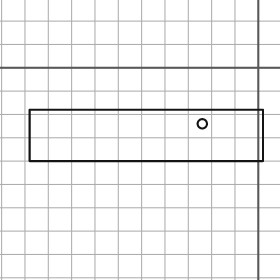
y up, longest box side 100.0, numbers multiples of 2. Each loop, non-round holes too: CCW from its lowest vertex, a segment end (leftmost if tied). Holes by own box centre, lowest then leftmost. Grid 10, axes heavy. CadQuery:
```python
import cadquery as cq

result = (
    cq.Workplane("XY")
    .moveTo(-98.0, -40.0)
    .lineTo(2.0, -40.0)
    .lineTo(2.0, -18.0)
    .lineTo(-98.0, -18.0)
    .close()
    .moveTo(-24.0, -24.0)
    .circle(2.0)
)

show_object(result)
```